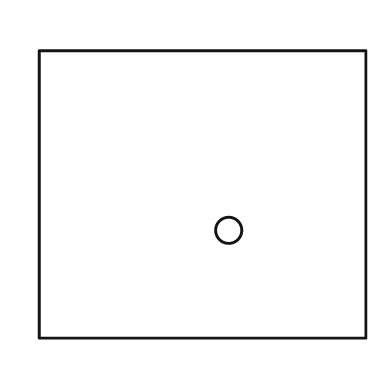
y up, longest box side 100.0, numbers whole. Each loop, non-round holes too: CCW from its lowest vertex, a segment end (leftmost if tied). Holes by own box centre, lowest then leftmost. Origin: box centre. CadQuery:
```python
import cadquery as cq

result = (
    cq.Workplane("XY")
    .moveTo(-50.0, -44.0)
    .lineTo(50.0, -44.0)
    .lineTo(50.0, 44.0)
    .lineTo(-50.0, 44.0)
    .close()
    .moveTo(8.0, -11.0)
    .circle(4.0)
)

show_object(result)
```